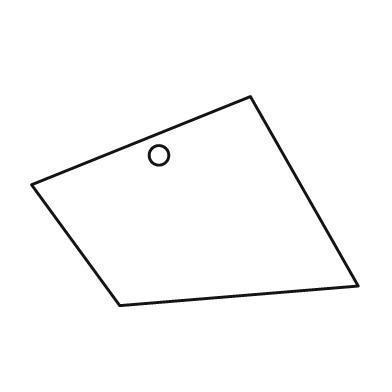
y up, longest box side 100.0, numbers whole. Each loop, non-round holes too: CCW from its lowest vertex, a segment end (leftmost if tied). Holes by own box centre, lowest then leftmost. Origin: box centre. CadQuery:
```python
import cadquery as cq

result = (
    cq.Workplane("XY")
    .moveTo(-23.0, -32.0)
    .lineTo(50.0, -26.0)
    .lineTo(17.0, 32.0)
    .lineTo(-50.0, 5.0)
    .close()
    .moveTo(-11.0, 14.0)
    .circle(3.0)
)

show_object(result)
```